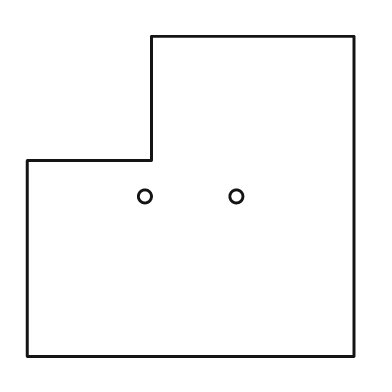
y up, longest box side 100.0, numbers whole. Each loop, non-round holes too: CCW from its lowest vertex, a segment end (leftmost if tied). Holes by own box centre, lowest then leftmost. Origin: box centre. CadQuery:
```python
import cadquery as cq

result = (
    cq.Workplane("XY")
    .moveTo(-50.0, -49.0)
    .lineTo(50.0, -49.0)
    .lineTo(50.0, 49.0)
    .lineTo(-12.0, 49.0)
    .lineTo(-12.0, 11.0)
    .lineTo(-50.0, 11.0)
    .close()
    .moveTo(-14.0, 0.0)
    .circle(2.0)
    .moveTo(14.0, 0.0)
    .circle(2.0)
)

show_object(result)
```